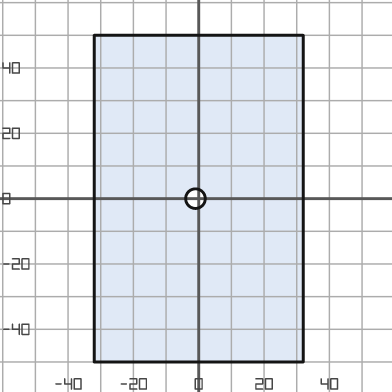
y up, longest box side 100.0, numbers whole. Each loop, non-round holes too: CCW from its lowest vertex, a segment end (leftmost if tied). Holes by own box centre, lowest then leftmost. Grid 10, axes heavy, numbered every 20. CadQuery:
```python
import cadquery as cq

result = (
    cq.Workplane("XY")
    .moveTo(-32.0, -50.0)
    .lineTo(32.0, -50.0)
    .lineTo(32.0, 50.0)
    .lineTo(-32.0, 50.0)
    .close()
    .moveTo(-1.0, 0.0)
    .circle(3.0)
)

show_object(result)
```